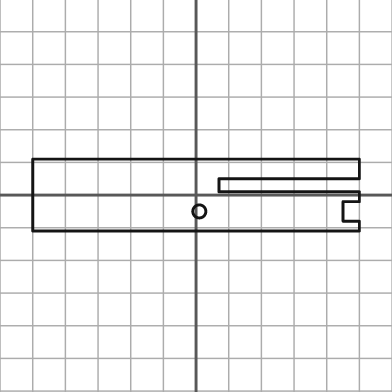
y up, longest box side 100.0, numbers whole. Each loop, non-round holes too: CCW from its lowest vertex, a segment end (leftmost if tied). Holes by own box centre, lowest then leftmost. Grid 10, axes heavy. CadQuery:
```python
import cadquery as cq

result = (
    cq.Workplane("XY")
    .moveTo(-50.0, -11.0)
    .lineTo(50.0, -11.0)
    .lineTo(50.0, -8.0)
    .lineTo(45.0, -8.0)
    .lineTo(45.0, -2.0)
    .lineTo(50.0, -2.0)
    .lineTo(50.0, 1.0)
    .lineTo(7.0, 1.0)
    .lineTo(7.0, 5.0)
    .lineTo(50.0, 5.0)
    .lineTo(50.0, 11.0)
    .lineTo(-50.0, 11.0)
    .close()
    .moveTo(1.0, -5.0)
    .circle(2.0)
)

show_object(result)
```